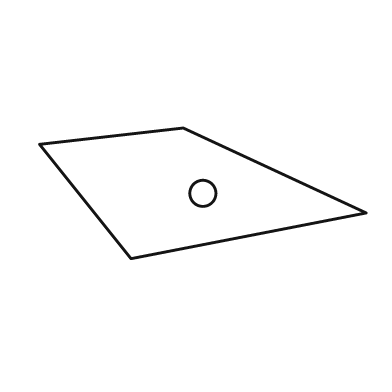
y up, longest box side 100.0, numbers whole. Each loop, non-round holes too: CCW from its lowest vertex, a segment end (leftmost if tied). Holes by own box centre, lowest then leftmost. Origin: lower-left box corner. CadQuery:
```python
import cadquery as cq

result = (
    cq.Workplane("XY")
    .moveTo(28.0, 0.0)
    .lineTo(100.0, 14.0)
    .lineTo(44.0, 40.0)
    .lineTo(0.0, 35.0)
    .close()
    .moveTo(50.0, 20.0)
    .circle(4.0)
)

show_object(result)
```